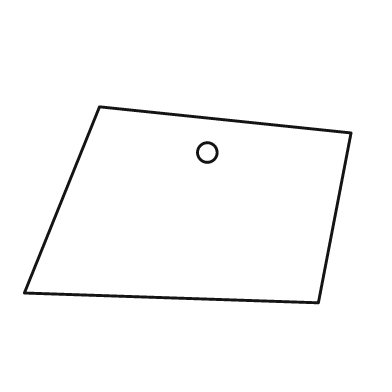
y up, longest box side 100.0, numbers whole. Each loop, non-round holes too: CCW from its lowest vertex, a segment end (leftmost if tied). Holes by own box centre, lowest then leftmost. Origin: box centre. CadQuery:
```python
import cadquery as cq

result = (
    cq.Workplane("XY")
    .moveTo(40.0, -30.0)
    .lineTo(50.0, 22.0)
    .lineTo(-27.0, 30.0)
    .lineTo(-50.0, -27.0)
    .close()
    .moveTo(6.0, 16.0)
    .circle(3.0)
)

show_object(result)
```